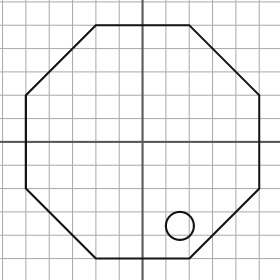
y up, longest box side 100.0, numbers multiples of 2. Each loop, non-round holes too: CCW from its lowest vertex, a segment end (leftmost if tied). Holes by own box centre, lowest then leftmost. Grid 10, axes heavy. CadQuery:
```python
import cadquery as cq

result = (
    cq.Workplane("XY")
    .moveTo(-20.0, -50.0)
    .lineTo(20.0, -50.0)
    .lineTo(50.0, -20.0)
    .lineTo(50.0, 20.0)
    .lineTo(20.0, 50.0)
    .lineTo(-20.0, 50.0)
    .lineTo(-50.0, 20.0)
    .lineTo(-50.0, -20.0)
    .close()
    .moveTo(16.0, -36.0)
    .circle(6.0)
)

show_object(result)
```